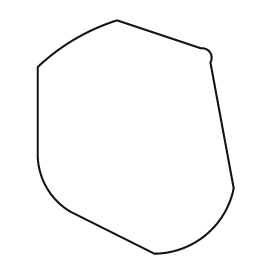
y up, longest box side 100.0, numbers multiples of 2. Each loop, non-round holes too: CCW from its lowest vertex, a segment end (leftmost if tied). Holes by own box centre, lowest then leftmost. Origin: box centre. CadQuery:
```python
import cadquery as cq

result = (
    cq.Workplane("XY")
    .moveTo(8.0, -50.0)
    .threePointArc((30.0, -42.0), (42.0, -22.0))
    .lineTo(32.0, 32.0)
    .threePointArc((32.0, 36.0), (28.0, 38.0))
    .lineTo(-8.0, 50.0)
    .threePointArc((-26.0, 42.0), (-42.0, 30.0))
    .lineTo(-42.0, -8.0)
    .threePointArc((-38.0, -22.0), (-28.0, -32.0))
    .close()
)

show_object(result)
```